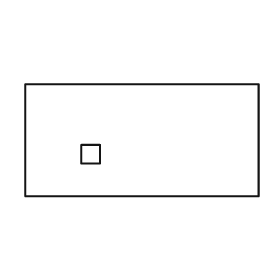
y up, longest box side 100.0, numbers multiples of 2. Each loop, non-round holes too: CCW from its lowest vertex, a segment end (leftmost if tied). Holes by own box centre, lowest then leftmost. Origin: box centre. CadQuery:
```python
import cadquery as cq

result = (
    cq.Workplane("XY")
    .moveTo(-50.0, -24.0)
    .lineTo(50.0, -24.0)
    .lineTo(50.0, 24.0)
    .lineTo(-50.0, 24.0)
    .close()
    .moveTo(-26.0, -10.0)
    .lineTo(-18.0, -10.0)
    .lineTo(-18.0, -2.0)
    .lineTo(-26.0, -2.0)
    .close()
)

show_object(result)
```